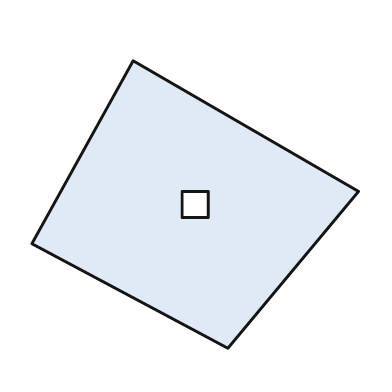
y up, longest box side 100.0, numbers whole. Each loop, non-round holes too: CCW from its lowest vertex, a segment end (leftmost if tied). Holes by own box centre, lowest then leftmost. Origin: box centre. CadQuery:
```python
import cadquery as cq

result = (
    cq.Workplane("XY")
    .moveTo(10.0, -44.0)
    .lineTo(50.0, 4.0)
    .lineTo(-19.0, 44.0)
    .lineTo(-50.0, -12.0)
    .close()
    .moveTo(-4.0, -4.0)
    .lineTo(4.0, -4.0)
    .lineTo(4.0, 4.0)
    .lineTo(-4.0, 4.0)
    .close()
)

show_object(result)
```